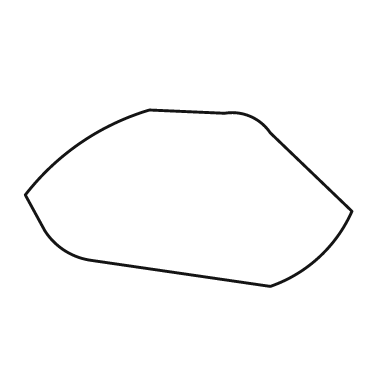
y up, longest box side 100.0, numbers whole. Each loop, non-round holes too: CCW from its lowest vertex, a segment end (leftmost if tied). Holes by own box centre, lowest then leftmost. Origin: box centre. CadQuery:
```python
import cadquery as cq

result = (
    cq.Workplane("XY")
    .moveTo(25.0, -27.0)
    .threePointArc((40.0, -18.0), (50.0, -4.0))
    .lineTo(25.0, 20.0)
    .threePointArc((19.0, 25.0), (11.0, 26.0))
    .lineTo(-12.0, 27.0)
    .threePointArc((-33.0, 17.0), (-50.0, 1.0))
    .lineTo(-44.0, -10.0)
    .threePointArc((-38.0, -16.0), (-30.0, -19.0))
    .close()
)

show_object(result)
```